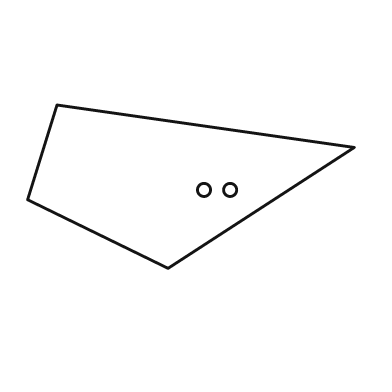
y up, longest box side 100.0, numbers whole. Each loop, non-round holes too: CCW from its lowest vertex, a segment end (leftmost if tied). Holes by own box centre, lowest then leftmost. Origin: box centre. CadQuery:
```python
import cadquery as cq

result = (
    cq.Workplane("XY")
    .moveTo(-7.0, -25.0)
    .lineTo(50.0, 12.0)
    .lineTo(-41.0, 25.0)
    .lineTo(-50.0, -4.0)
    .close()
    .moveTo(4.0, -1.0)
    .circle(2.0)
    .moveTo(12.0, -1.0)
    .circle(2.0)
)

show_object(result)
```